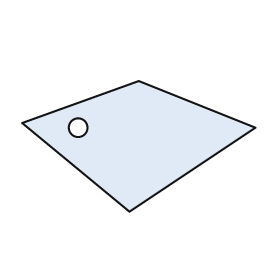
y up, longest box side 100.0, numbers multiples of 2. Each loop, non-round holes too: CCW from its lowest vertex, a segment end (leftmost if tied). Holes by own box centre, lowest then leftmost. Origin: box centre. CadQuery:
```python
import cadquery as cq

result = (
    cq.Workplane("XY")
    .moveTo(-4.0, -28.0)
    .lineTo(50.0, 8.0)
    .lineTo(0.0, 28.0)
    .lineTo(-50.0, 10.0)
    .close()
    .moveTo(-26.0, 8.0)
    .circle(4.0)
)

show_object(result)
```